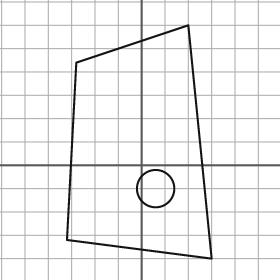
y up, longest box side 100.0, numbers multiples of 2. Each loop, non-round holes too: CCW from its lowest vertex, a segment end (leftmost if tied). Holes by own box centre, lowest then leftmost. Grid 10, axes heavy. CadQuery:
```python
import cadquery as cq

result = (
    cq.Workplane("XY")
    .moveTo(30.0, -40.0)
    .lineTo(20.0, 60.0)
    .lineTo(-28.0, 44.0)
    .lineTo(-32.0, -32.0)
    .close()
    .moveTo(6.0, -10.0)
    .circle(8.0)
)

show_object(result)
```